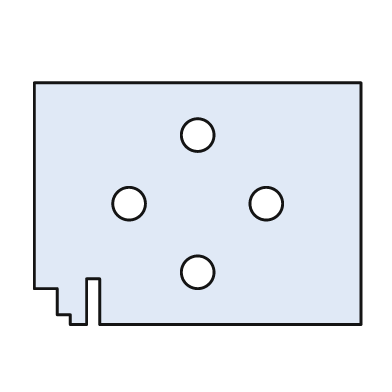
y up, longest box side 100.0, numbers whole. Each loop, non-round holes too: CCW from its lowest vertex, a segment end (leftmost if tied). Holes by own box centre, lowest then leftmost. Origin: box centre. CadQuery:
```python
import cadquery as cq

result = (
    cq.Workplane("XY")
    .moveTo(-39.0, -37.0)
    .lineTo(-34.0, -37.0)
    .lineTo(-34.0, -23.0)
    .lineTo(-30.0, -23.0)
    .lineTo(-30.0, -37.0)
    .lineTo(50.0, -37.0)
    .lineTo(50.0, 37.0)
    .lineTo(-50.0, 37.0)
    .lineTo(-50.0, -26.0)
    .lineTo(-43.0, -26.0)
    .lineTo(-43.0, -34.0)
    .lineTo(-39.0, -34.0)
    .close()
    .moveTo(0.0, -21.0)
    .circle(5.0)
    .moveTo(-21.0, 0.0)
    .circle(5.0)
    .moveTo(21.0, 0.0)
    .circle(5.0)
    .moveTo(0.0, 21.0)
    .circle(5.0)
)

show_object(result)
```